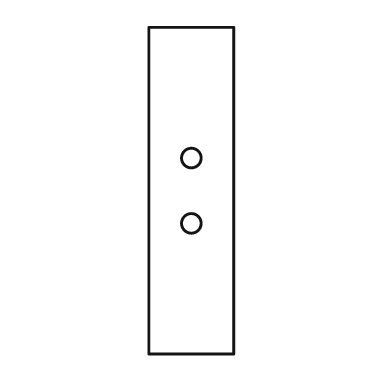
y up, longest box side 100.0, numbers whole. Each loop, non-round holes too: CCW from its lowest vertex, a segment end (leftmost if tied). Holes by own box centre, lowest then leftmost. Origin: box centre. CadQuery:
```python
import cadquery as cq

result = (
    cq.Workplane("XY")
    .moveTo(-13.0, -50.0)
    .lineTo(13.0, -50.0)
    .lineTo(13.0, 50.0)
    .lineTo(-13.0, 50.0)
    .close()
    .moveTo(0.0, -10.0)
    .circle(3.0)
    .moveTo(0.0, 10.0)
    .circle(3.0)
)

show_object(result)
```